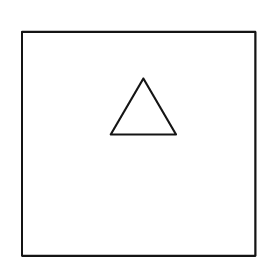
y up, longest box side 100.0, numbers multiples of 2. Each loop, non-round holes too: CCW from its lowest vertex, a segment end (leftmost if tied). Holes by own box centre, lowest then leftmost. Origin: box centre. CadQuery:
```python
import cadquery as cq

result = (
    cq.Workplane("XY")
    .moveTo(-50.0, -48.0)
    .lineTo(50.0, -48.0)
    .lineTo(50.0, 48.0)
    .lineTo(-50.0, 48.0)
    .close()
    .moveTo(-12.0, 4.0)
    .lineTo(16.0, 4.0)
    .lineTo(2.0, 28.0)
    .close()
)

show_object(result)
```